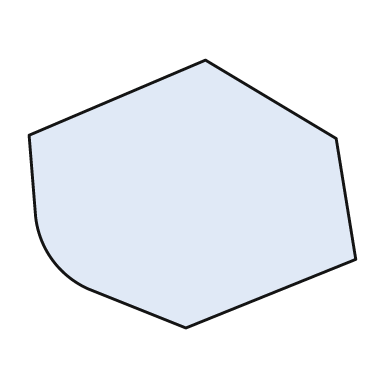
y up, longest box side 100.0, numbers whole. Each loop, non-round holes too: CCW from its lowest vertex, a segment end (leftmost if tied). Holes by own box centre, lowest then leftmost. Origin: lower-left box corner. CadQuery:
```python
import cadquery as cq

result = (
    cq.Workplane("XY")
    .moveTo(48.0, 0.0)
    .lineTo(100.0, 21.0)
    .lineTo(94.0, 58.0)
    .lineTo(54.0, 82.0)
    .lineTo(0.0, 59.0)
    .lineTo(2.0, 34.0)
    .threePointArc((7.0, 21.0), (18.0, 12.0))
    .close()
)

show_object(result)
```